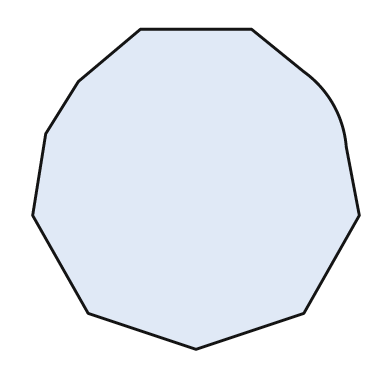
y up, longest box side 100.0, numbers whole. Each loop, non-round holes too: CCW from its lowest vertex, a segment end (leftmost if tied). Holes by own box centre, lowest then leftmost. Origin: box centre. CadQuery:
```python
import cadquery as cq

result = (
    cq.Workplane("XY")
    .moveTo(0.0, -49.0)
    .lineTo(33.0, -38.0)
    .lineTo(50.0, -8.0)
    .lineTo(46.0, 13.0)
    .threePointArc((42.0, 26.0), (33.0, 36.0))
    .lineTo(17.0, 49.0)
    .lineTo(-17.0, 49.0)
    .lineTo(-36.0, 33.0)
    .lineTo(-46.0, 17.0)
    .lineTo(-50.0, -8.0)
    .lineTo(-33.0, -38.0)
    .close()
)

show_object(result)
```